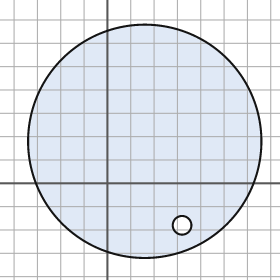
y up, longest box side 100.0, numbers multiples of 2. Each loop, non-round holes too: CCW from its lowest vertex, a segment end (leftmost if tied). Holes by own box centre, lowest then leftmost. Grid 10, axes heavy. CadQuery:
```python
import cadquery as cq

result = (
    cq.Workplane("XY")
    .moveTo(16.0, 18.0)
    .circle(50.0)
    .moveTo(32.0, -18.0)
    .circle(4.0)
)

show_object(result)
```